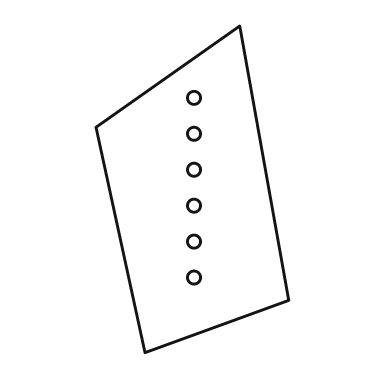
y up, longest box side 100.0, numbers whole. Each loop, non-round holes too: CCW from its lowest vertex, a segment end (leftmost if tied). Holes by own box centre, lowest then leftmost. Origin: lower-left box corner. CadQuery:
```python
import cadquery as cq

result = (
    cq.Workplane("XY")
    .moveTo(15.0, 0.0)
    .lineTo(59.0, 16.0)
    .lineTo(44.0, 100.0)
    .lineTo(0.0, 69.0)
    .close()
    .moveTo(30.0, 23.0)
    .circle(2.0)
    .moveTo(30.0, 34.0)
    .circle(2.0)
    .moveTo(30.0, 45.0)
    .circle(2.0)
    .moveTo(30.0, 56.0)
    .circle(2.0)
    .moveTo(30.0, 67.0)
    .circle(2.0)
    .moveTo(30.0, 78.0)
    .circle(2.0)
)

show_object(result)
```